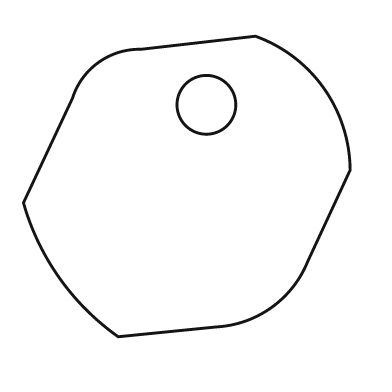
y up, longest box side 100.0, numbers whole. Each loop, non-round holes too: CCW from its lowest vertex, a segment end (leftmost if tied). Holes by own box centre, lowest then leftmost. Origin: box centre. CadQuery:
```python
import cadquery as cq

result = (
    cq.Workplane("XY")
    .moveTo(-21.0, -46.0)
    .lineTo(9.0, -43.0)
    .threePointArc((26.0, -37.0), (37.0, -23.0))
    .lineTo(50.0, 5.0)
    .threePointArc((42.0, 30.0), (21.0, 46.0))
    .lineTo(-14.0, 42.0)
    .threePointArc((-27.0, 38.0), (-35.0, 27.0))
    .lineTo(-50.0, -5.0)
    .threePointArc((-39.0, -28.0), (-21.0, -46.0))
    .close()
    .moveTo(6.0, 25.0)
    .circle(9.0)
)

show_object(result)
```